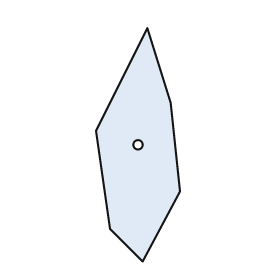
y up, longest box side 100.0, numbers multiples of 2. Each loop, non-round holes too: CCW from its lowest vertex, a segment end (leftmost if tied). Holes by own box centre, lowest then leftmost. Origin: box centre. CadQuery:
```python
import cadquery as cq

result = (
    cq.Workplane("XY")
    .moveTo(2.0, -50.0)
    .lineTo(18.0, -20.0)
    .lineTo(14.0, 18.0)
    .lineTo(4.0, 50.0)
    .lineTo(-18.0, 6.0)
    .lineTo(-12.0, -36.0)
    .close()
    .moveTo(0.0, 0.0)
    .circle(2.0)
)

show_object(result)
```